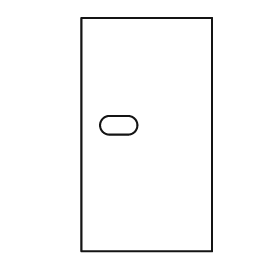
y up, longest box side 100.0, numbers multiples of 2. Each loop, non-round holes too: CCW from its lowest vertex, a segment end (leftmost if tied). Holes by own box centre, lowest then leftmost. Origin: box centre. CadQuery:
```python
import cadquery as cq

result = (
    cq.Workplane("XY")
    .moveTo(-28.0, -50.0)
    .lineTo(28.0, -50.0)
    .lineTo(28.0, 50.0)
    .lineTo(-28.0, 50.0)
    .close()
    .moveTo(-16.0, 0.0)
    .lineTo(-8.0, 0.0)
    .threePointArc((-4.0, 4.0), (-8.0, 8.0))
    .lineTo(-16.0, 8.0)
    .threePointArc((-20.0, 4.0), (-16.0, 0.0))
    .close()
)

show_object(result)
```